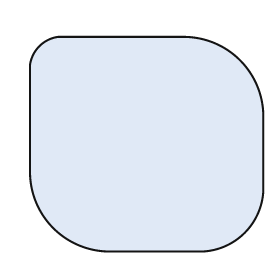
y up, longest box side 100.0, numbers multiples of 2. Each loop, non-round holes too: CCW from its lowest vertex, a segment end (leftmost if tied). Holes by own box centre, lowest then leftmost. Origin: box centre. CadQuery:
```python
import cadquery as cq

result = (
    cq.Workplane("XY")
    .moveTo(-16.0, -46.0)
    .lineTo(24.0, -46.0)
    .threePointArc((42.0, -38.0), (50.0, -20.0))
    .lineTo(50.0, 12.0)
    .threePointArc((40.0, 36.0), (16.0, 46.0))
    .lineTo(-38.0, 46.0)
    .threePointArc((-46.0, 42.0), (-50.0, 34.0))
    .lineTo(-50.0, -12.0)
    .threePointArc((-40.0, -36.0), (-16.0, -46.0))
    .close()
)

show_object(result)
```